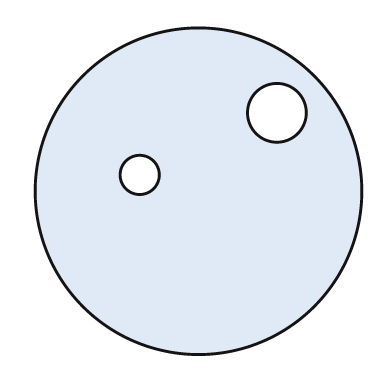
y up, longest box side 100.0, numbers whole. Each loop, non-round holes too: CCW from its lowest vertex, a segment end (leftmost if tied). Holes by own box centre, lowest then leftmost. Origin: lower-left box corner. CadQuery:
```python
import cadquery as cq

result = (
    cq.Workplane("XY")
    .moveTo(50.0, 50.0)
    .circle(50.0)
    .moveTo(32.0, 55.0)
    .circle(6.0)
    .moveTo(74.0, 74.0)
    .circle(9.0)
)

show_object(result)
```